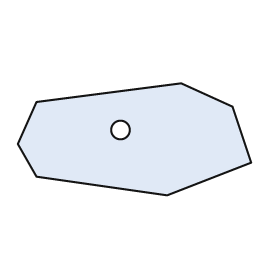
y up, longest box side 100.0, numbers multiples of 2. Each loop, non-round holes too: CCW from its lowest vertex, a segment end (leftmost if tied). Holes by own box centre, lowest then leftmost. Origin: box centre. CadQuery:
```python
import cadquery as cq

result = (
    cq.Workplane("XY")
    .moveTo(14.0, -24.0)
    .lineTo(50.0, -10.0)
    .lineTo(42.0, 14.0)
    .lineTo(20.0, 24.0)
    .lineTo(-42.0, 16.0)
    .lineTo(-50.0, -2.0)
    .lineTo(-42.0, -16.0)
    .close()
    .moveTo(-6.0, 4.0)
    .circle(4.0)
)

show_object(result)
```